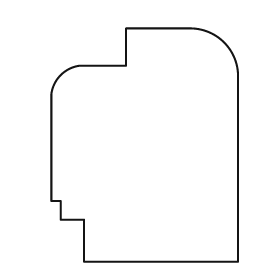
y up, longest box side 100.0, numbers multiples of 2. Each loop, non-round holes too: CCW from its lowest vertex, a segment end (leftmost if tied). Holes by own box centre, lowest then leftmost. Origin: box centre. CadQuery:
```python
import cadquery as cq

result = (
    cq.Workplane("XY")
    .moveTo(-26.0, -50.0)
    .lineTo(40.0, -50.0)
    .lineTo(40.0, 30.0)
    .threePointArc((34.0, 44.0), (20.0, 50.0))
    .lineTo(-8.0, 50.0)
    .lineTo(-8.0, 34.0)
    .lineTo(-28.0, 34.0)
    .threePointArc((-36.0, 30.0), (-40.0, 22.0))
    .lineTo(-40.0, -24.0)
    .lineTo(-36.0, -24.0)
    .lineTo(-36.0, -32.0)
    .lineTo(-26.0, -32.0)
    .close()
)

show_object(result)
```